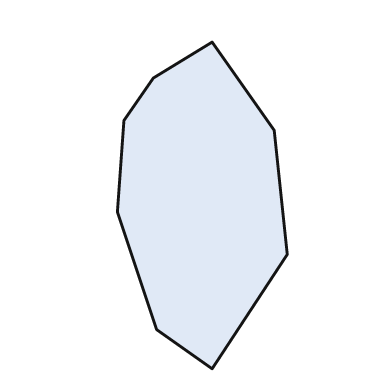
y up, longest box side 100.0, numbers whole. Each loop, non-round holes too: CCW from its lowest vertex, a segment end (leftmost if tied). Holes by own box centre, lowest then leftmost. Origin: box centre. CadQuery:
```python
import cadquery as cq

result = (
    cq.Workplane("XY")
    .moveTo(3.0, -50.0)
    .lineTo(26.0, -15.0)
    .lineTo(22.0, 23.0)
    .lineTo(3.0, 50.0)
    .lineTo(-15.0, 39.0)
    .lineTo(-24.0, 26.0)
    .lineTo(-26.0, -2.0)
    .lineTo(-14.0, -38.0)
    .close()
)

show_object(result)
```